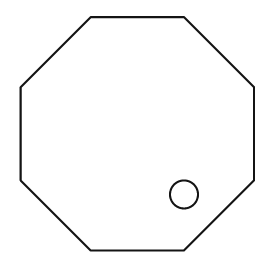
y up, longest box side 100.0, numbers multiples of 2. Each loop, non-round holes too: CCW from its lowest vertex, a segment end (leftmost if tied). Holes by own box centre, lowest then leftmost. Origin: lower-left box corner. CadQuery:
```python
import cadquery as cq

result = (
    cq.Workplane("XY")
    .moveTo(30.0, 0.0)
    .lineTo(70.0, 0.0)
    .lineTo(100.0, 30.0)
    .lineTo(100.0, 70.0)
    .lineTo(70.0, 100.0)
    .lineTo(30.0, 100.0)
    .lineTo(0.0, 70.0)
    .lineTo(0.0, 30.0)
    .close()
    .moveTo(70.0, 24.0)
    .circle(6.0)
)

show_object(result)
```